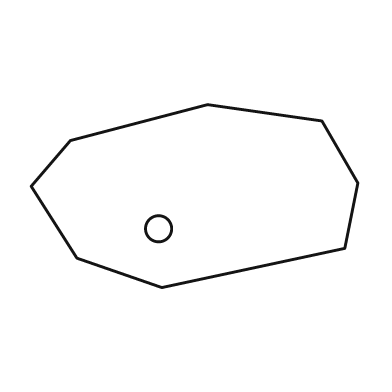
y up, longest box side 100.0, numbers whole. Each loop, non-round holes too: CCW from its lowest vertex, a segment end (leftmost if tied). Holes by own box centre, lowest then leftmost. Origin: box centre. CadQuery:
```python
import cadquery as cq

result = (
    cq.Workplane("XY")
    .moveTo(-10.0, -28.0)
    .lineTo(46.0, -16.0)
    .lineTo(50.0, 4.0)
    .lineTo(39.0, 23.0)
    .lineTo(4.0, 28.0)
    .lineTo(-38.0, 17.0)
    .lineTo(-50.0, 3.0)
    .lineTo(-36.0, -19.0)
    .close()
    .moveTo(-11.0, -10.0)
    .circle(4.0)
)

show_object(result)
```